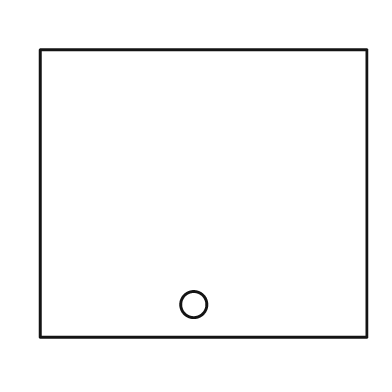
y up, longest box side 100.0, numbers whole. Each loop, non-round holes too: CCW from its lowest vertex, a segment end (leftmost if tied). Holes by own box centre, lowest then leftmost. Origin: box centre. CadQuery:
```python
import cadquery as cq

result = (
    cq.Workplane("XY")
    .moveTo(-50.0, -44.0)
    .lineTo(50.0, -44.0)
    .lineTo(50.0, 44.0)
    .lineTo(-50.0, 44.0)
    .close()
    .moveTo(-3.0, -34.0)
    .circle(4.0)
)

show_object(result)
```